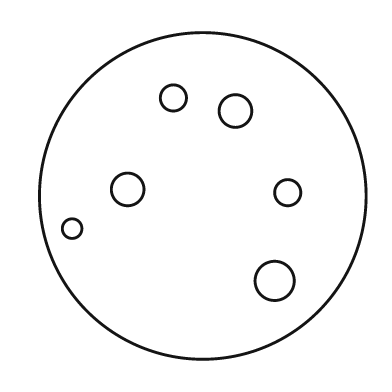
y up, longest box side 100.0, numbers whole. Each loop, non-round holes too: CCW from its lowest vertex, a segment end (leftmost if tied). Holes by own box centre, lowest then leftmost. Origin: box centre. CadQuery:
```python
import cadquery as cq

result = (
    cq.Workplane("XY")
    .moveTo(0.0, 0.0)
    .circle(50.0)
    .moveTo(22.0, -26.0)
    .circle(6.0)
    .moveTo(-40.0, -10.0)
    .circle(3.0)
    .moveTo(26.0, 1.0)
    .circle(4.0)
    .moveTo(-23.0, 2.0)
    .circle(5.0)
    .moveTo(10.0, 26.0)
    .circle(5.0)
    .moveTo(-9.0, 30.0)
    .circle(4.0)
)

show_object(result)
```